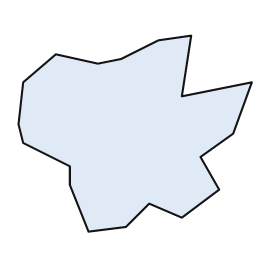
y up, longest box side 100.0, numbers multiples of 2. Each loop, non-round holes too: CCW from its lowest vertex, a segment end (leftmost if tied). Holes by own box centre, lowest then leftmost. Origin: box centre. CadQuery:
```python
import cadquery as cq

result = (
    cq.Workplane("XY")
    .moveTo(-20.0, -42.0)
    .lineTo(-4.0, -40.0)
    .lineTo(6.0, -30.0)
    .lineTo(20.0, -36.0)
    .lineTo(36.0, -24.0)
    .lineTo(28.0, -10.0)
    .lineTo(42.0, 0.0)
    .lineTo(50.0, 22.0)
    .lineTo(20.0, 16.0)
    .lineTo(24.0, 42.0)
    .lineTo(10.0, 40.0)
    .lineTo(-6.0, 32.0)
    .lineTo(-16.0, 30.0)
    .lineTo(-34.0, 34.0)
    .lineTo(-48.0, 22.0)
    .lineTo(-50.0, 4.0)
    .lineTo(-48.0, -4.0)
    .lineTo(-28.0, -14.0)
    .lineTo(-28.0, -22.0)
    .close()
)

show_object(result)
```